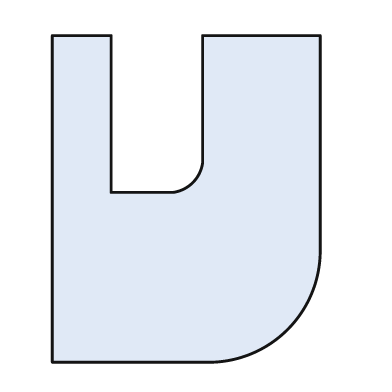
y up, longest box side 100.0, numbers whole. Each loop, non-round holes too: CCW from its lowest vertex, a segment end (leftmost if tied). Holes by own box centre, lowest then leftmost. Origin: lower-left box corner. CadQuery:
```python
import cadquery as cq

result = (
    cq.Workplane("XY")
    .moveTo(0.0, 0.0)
    .lineTo(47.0, 0.0)
    .threePointArc((72.0, 10.0), (82.0, 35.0))
    .lineTo(82.0, 100.0)
    .lineTo(46.0, 100.0)
    .lineTo(46.0, 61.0)
    .threePointArc((43.0, 55.0), (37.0, 52.0))
    .lineTo(18.0, 52.0)
    .lineTo(18.0, 100.0)
    .lineTo(0.0, 100.0)
    .close()
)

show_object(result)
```